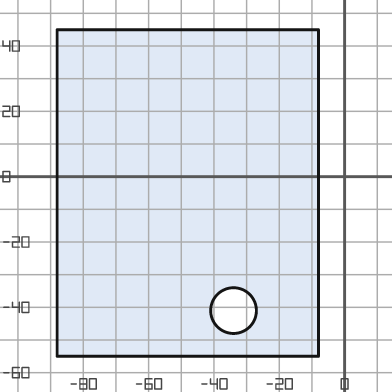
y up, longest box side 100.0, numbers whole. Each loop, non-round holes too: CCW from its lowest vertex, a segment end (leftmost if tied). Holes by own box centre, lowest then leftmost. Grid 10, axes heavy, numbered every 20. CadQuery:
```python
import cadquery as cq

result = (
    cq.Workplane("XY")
    .moveTo(-88.0, -55.0)
    .lineTo(-8.0, -55.0)
    .lineTo(-8.0, 45.0)
    .lineTo(-88.0, 45.0)
    .close()
    .moveTo(-34.0, -41.0)
    .circle(7.0)
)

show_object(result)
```